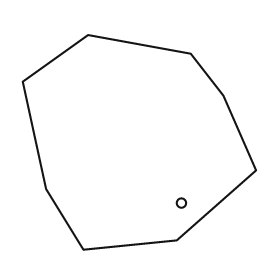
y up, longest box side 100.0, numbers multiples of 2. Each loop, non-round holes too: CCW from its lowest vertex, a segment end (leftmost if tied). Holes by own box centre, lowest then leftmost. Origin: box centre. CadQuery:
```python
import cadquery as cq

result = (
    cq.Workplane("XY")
    .moveTo(-24.0, -46.0)
    .lineTo(16.0, -42.0)
    .lineTo(50.0, -12.0)
    .lineTo(36.0, 20.0)
    .lineTo(22.0, 38.0)
    .lineTo(-22.0, 46.0)
    .lineTo(-50.0, 26.0)
    .lineTo(-40.0, -20.0)
    .close()
    .moveTo(18.0, -26.0)
    .circle(2.0)
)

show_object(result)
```